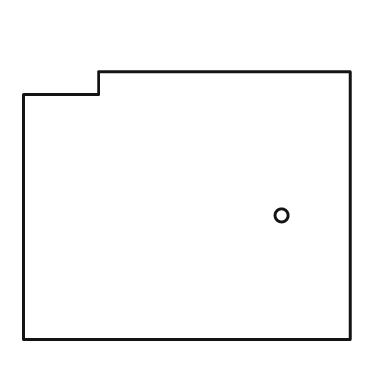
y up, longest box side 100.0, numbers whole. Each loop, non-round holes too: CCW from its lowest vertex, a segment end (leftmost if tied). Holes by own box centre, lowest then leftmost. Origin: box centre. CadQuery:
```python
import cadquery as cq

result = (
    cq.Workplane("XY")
    .moveTo(-50.0, -41.0)
    .lineTo(50.0, -41.0)
    .lineTo(50.0, 41.0)
    .lineTo(-27.0, 41.0)
    .lineTo(-27.0, 34.0)
    .lineTo(-50.0, 34.0)
    .close()
    .moveTo(29.0, -3.0)
    .circle(2.0)
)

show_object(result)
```